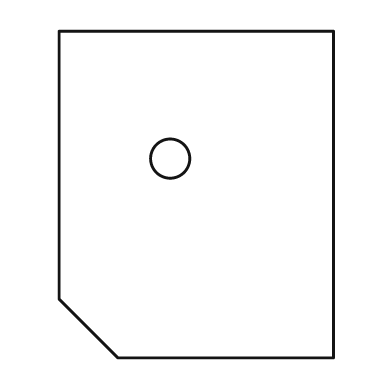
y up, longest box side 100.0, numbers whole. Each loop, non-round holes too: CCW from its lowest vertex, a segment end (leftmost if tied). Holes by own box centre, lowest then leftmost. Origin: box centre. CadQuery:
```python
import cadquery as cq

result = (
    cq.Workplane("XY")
    .moveTo(-24.0, -50.0)
    .lineTo(42.0, -50.0)
    .lineTo(42.0, 50.0)
    .lineTo(-42.0, 50.0)
    .lineTo(-42.0, -32.0)
    .close()
    .moveTo(-8.0, 11.0)
    .circle(6.0)
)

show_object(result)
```